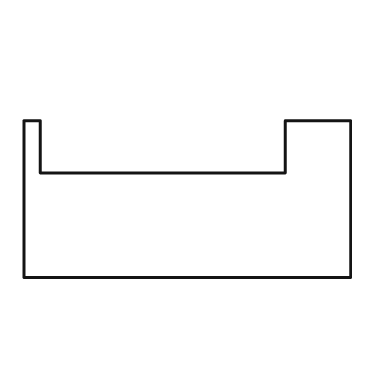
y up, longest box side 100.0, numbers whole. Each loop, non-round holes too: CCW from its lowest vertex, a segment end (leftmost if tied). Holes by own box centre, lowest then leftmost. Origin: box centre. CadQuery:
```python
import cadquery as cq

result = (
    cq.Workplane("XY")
    .moveTo(-50.0, -24.0)
    .lineTo(50.0, -24.0)
    .lineTo(50.0, 24.0)
    .lineTo(30.0, 24.0)
    .lineTo(30.0, 8.0)
    .lineTo(-45.0, 8.0)
    .lineTo(-45.0, 24.0)
    .lineTo(-50.0, 24.0)
    .close()
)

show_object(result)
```